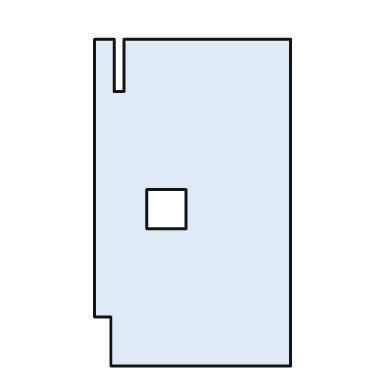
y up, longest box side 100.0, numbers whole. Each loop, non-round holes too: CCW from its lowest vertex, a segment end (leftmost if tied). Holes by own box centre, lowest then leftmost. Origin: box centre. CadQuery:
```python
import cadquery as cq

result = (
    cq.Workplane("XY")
    .moveTo(-25.0, -50.0)
    .lineTo(30.0, -50.0)
    .lineTo(30.0, 50.0)
    .lineTo(-21.0, 50.0)
    .lineTo(-21.0, 34.0)
    .lineTo(-24.0, 34.0)
    .lineTo(-24.0, 50.0)
    .lineTo(-30.0, 50.0)
    .lineTo(-30.0, -35.0)
    .lineTo(-25.0, -35.0)
    .close()
    .moveTo(-14.0, -8.0)
    .lineTo(-2.0, -8.0)
    .lineTo(-2.0, 4.0)
    .lineTo(-14.0, 4.0)
    .close()
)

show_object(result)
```